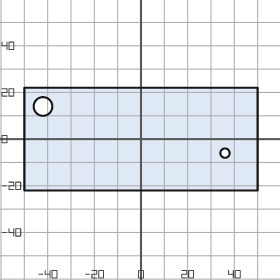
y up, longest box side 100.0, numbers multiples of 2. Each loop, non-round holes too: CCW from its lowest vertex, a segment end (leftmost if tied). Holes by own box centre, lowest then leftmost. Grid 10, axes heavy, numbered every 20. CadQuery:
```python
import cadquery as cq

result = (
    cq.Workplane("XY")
    .moveTo(-50.0, -22.0)
    .lineTo(50.0, -22.0)
    .lineTo(50.0, 22.0)
    .lineTo(-50.0, 22.0)
    .close()
    .moveTo(36.0, -6.0)
    .circle(2.0)
    .moveTo(-42.0, 14.0)
    .circle(4.0)
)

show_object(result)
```